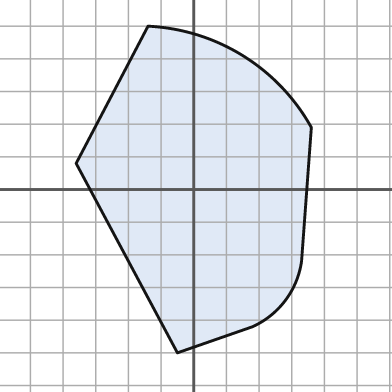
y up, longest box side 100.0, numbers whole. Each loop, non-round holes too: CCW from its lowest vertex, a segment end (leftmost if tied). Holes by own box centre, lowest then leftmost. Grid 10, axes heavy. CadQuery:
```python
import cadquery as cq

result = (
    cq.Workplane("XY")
    .moveTo(-5.0, -50.0)
    .lineTo(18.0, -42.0)
    .threePointArc((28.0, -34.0), (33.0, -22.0))
    .lineTo(36.0, 19.0)
    .threePointArc((15.0, 41.0), (-14.0, 50.0))
    .lineTo(-36.0, 8.0)
    .close()
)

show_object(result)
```